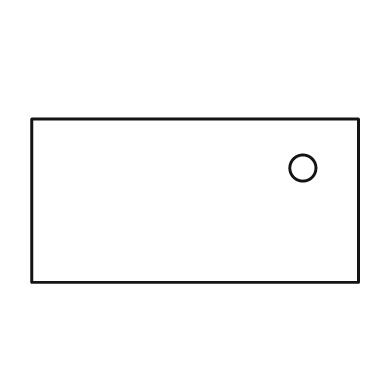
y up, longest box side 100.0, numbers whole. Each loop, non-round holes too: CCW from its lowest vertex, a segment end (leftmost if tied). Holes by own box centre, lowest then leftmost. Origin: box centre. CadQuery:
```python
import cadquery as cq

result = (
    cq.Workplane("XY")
    .moveTo(-50.0, -25.0)
    .lineTo(50.0, -25.0)
    .lineTo(50.0, 25.0)
    .lineTo(-50.0, 25.0)
    .close()
    .moveTo(33.0, 10.0)
    .circle(4.0)
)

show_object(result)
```